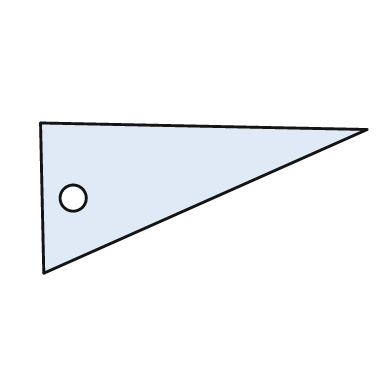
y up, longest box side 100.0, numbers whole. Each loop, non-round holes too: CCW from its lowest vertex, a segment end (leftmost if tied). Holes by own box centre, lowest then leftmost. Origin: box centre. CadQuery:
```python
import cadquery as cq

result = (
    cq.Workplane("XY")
    .moveTo(-49.0, -23.0)
    .lineTo(50.0, 21.0)
    .lineTo(-50.0, 23.0)
    .close()
    .moveTo(-40.0, 0.0)
    .circle(4.0)
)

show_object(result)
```